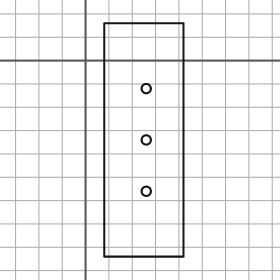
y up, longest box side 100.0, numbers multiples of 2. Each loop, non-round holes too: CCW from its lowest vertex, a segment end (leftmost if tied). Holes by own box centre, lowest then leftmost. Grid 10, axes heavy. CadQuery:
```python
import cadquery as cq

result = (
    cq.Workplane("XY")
    .moveTo(8.0, -84.0)
    .lineTo(42.0, -84.0)
    .lineTo(42.0, 16.0)
    .lineTo(8.0, 16.0)
    .close()
    .moveTo(26.0, -56.0)
    .circle(2.0)
    .moveTo(26.0, -34.0)
    .circle(2.0)
    .moveTo(26.0, -12.0)
    .circle(2.0)
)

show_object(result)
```